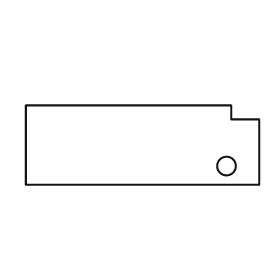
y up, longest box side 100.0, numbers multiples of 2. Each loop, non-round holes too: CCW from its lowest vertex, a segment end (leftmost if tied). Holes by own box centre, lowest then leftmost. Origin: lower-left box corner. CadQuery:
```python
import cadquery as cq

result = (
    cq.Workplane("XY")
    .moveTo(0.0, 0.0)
    .lineTo(100.0, 0.0)
    .lineTo(100.0, 28.0)
    .lineTo(88.0, 28.0)
    .lineTo(88.0, 34.0)
    .lineTo(0.0, 34.0)
    .close()
    .moveTo(86.0, 8.0)
    .circle(4.0)
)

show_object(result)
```